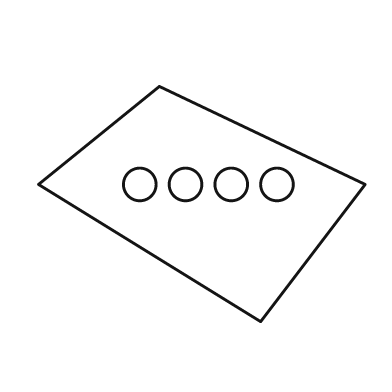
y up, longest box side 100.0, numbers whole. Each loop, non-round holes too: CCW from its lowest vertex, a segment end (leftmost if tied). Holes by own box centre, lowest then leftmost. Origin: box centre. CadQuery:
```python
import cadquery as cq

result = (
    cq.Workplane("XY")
    .moveTo(18.0, -36.0)
    .lineTo(50.0, 6.0)
    .lineTo(-13.0, 36.0)
    .lineTo(-50.0, 6.0)
    .close()
    .moveTo(-19.0, 6.0)
    .circle(5.0)
    .moveTo(-5.0, 6.0)
    .circle(5.0)
    .moveTo(9.0, 6.0)
    .circle(5.0)
    .moveTo(23.0, 6.0)
    .circle(5.0)
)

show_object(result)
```